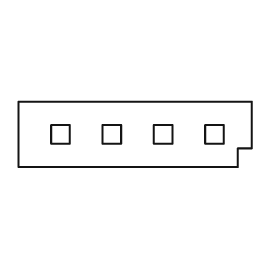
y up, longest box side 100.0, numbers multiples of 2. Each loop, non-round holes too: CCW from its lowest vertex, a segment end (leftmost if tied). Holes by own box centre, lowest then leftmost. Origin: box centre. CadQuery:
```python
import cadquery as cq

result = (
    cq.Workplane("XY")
    .moveTo(-50.0, -14.0)
    .lineTo(44.0, -14.0)
    .lineTo(44.0, -6.0)
    .lineTo(50.0, -6.0)
    .lineTo(50.0, 14.0)
    .lineTo(-50.0, 14.0)
    .close()
    .moveTo(-36.0, -4.0)
    .lineTo(-28.0, -4.0)
    .lineTo(-28.0, 4.0)
    .lineTo(-36.0, 4.0)
    .close()
    .moveTo(-14.0, -4.0)
    .lineTo(-6.0, -4.0)
    .lineTo(-6.0, 4.0)
    .lineTo(-14.0, 4.0)
    .close()
    .moveTo(8.0, -4.0)
    .lineTo(16.0, -4.0)
    .lineTo(16.0, 4.0)
    .lineTo(8.0, 4.0)
    .close()
    .moveTo(30.0, -4.0)
    .lineTo(38.0, -4.0)
    .lineTo(38.0, 4.0)
    .lineTo(30.0, 4.0)
    .close()
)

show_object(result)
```